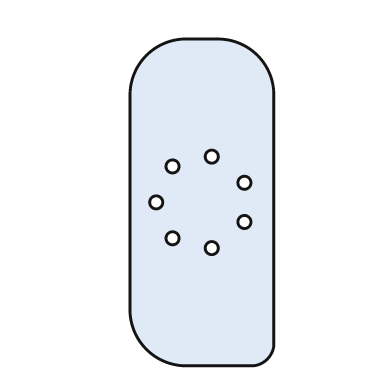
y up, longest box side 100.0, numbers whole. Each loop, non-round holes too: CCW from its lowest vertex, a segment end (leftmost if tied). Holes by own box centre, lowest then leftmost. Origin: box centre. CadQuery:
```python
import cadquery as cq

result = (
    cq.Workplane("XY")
    .moveTo(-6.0, -50.0)
    .lineTo(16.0, -50.0)
    .threePointArc((20.0, -48.0), (22.0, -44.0))
    .lineTo(22.0, 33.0)
    .threePointArc((17.0, 45.0), (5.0, 50.0))
    .lineTo(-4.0, 50.0)
    .threePointArc((-17.0, 45.0), (-22.0, 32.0))
    .lineTo(-22.0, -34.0)
    .threePointArc((-17.0, -45.0), (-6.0, -50.0))
    .close()
    .moveTo(3.0, -14.0)
    .circle(2.0)
    .moveTo(-9.0, -11.0)
    .circle(2.0)
    .moveTo(13.0, -6.0)
    .circle(2.0)
    .moveTo(-14.0, 0.0)
    .circle(2.0)
    .moveTo(13.0, 6.0)
    .circle(2.0)
    .moveTo(-9.0, 11.0)
    .circle(2.0)
    .moveTo(3.0, 14.0)
    .circle(2.0)
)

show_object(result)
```